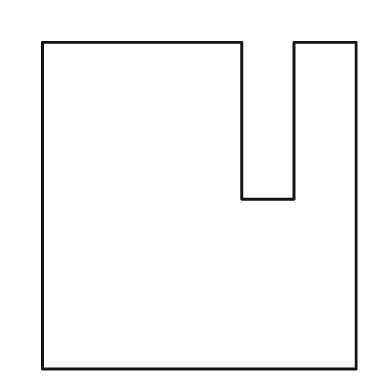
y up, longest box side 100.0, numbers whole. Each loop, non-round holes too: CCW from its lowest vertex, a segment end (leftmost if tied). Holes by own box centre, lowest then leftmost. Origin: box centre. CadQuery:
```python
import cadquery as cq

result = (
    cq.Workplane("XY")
    .moveTo(-48.0, -50.0)
    .lineTo(48.0, -50.0)
    .lineTo(48.0, 50.0)
    .lineTo(29.0, 50.0)
    .lineTo(29.0, 2.0)
    .lineTo(13.0, 2.0)
    .lineTo(13.0, 50.0)
    .lineTo(-48.0, 50.0)
    .close()
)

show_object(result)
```